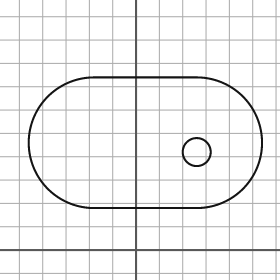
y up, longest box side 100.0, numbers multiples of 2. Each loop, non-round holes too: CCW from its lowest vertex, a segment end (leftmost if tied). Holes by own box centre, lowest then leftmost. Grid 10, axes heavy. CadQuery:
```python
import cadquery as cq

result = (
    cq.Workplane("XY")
    .moveTo(-18.0, 18.0)
    .lineTo(26.0, 18.0)
    .threePointArc((54.0, 46.0), (26.0, 74.0))
    .lineTo(-18.0, 74.0)
    .threePointArc((-46.0, 46.0), (-18.0, 18.0))
    .close()
    .moveTo(26.0, 42.0)
    .circle(6.0)
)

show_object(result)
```